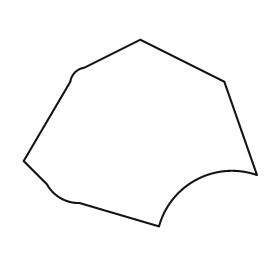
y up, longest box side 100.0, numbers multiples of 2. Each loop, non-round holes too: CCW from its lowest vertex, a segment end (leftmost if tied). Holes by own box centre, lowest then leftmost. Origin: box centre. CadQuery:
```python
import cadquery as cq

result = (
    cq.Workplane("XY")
    .moveTo(8.0, -40.0)
    .threePointArc((24.0, -20.0), (50.0, -18.0))
    .lineTo(36.0, 22.0)
    .lineTo(0.0, 40.0)
    .lineTo(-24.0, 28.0)
    .threePointArc((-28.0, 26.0), (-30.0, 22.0))
    .lineTo(-50.0, -12.0)
    .lineTo(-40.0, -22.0)
    .threePointArc((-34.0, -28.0), (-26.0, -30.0))
    .close()
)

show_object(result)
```